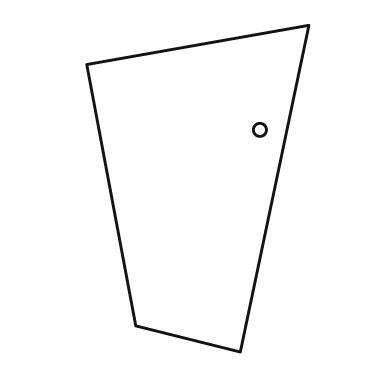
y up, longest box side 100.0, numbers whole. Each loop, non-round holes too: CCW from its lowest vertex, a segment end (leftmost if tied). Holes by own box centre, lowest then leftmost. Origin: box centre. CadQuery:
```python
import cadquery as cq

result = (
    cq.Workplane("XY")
    .moveTo(13.0, -50.0)
    .lineTo(34.0, 50.0)
    .lineTo(-34.0, 38.0)
    .lineTo(-19.0, -42.0)
    .close()
    .moveTo(19.0, 18.0)
    .circle(2.0)
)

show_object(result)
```